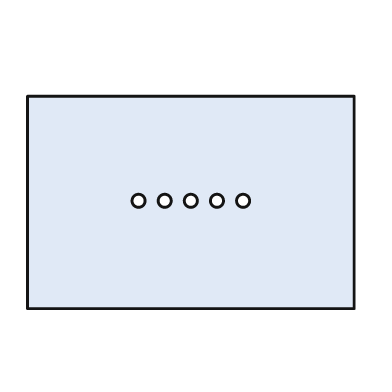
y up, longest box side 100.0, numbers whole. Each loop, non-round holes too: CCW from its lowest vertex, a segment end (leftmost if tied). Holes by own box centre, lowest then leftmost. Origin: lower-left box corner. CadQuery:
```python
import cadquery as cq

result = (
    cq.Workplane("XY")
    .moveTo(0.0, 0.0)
    .lineTo(100.0, 0.0)
    .lineTo(100.0, 65.0)
    .lineTo(0.0, 65.0)
    .close()
    .moveTo(34.0, 33.0)
    .circle(2.0)
    .moveTo(42.0, 33.0)
    .circle(2.0)
    .moveTo(50.0, 33.0)
    .circle(2.0)
    .moveTo(58.0, 33.0)
    .circle(2.0)
    .moveTo(66.0, 33.0)
    .circle(2.0)
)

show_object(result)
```